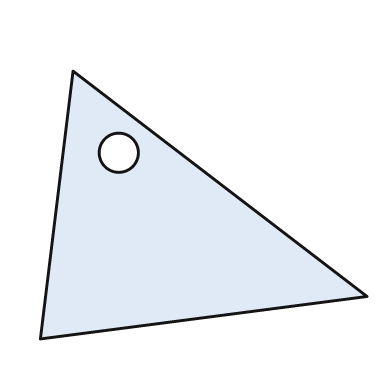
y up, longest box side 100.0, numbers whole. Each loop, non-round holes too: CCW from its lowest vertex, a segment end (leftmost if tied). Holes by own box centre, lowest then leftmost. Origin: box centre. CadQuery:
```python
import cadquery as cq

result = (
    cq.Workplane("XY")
    .moveTo(-50.0, -41.0)
    .lineTo(50.0, -28.0)
    .lineTo(-40.0, 41.0)
    .close()
    .moveTo(-26.0, 16.0)
    .circle(6.0)
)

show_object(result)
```